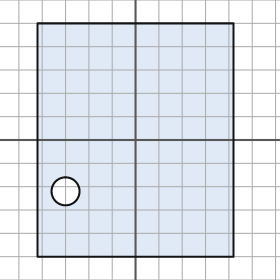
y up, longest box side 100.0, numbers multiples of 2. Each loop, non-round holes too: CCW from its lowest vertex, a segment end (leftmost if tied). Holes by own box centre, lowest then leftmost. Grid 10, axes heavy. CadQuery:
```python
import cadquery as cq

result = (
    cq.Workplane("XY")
    .moveTo(-42.0, -50.0)
    .lineTo(42.0, -50.0)
    .lineTo(42.0, 50.0)
    .lineTo(-42.0, 50.0)
    .close()
    .moveTo(-30.0, -22.0)
    .circle(6.0)
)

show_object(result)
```